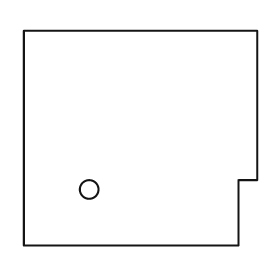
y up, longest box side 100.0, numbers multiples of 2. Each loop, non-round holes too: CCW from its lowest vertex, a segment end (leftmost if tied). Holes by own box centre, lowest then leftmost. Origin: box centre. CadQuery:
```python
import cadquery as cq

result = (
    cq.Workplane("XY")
    .moveTo(-50.0, -46.0)
    .lineTo(42.0, -46.0)
    .lineTo(42.0, -18.0)
    .lineTo(50.0, -18.0)
    .lineTo(50.0, 46.0)
    .lineTo(-50.0, 46.0)
    .close()
    .moveTo(-22.0, -22.0)
    .circle(4.0)
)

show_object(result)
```